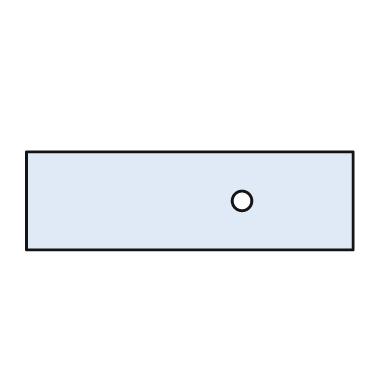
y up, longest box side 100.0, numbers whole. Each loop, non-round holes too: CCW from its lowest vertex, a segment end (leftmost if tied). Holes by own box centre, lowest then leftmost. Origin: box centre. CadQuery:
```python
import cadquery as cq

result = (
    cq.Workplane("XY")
    .moveTo(-50.0, -15.0)
    .lineTo(50.0, -15.0)
    .lineTo(50.0, 15.0)
    .lineTo(-50.0, 15.0)
    .close()
    .moveTo(16.0, 0.0)
    .circle(3.0)
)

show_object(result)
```